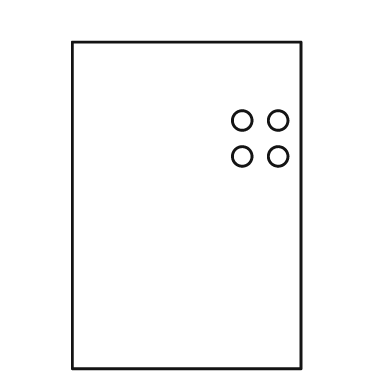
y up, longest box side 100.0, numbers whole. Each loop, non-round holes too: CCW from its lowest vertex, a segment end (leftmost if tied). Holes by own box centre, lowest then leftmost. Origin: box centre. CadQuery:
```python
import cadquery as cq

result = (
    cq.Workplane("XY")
    .moveTo(-35.0, -50.0)
    .lineTo(35.0, -50.0)
    .lineTo(35.0, 50.0)
    .lineTo(-35.0, 50.0)
    .close()
    .moveTo(17.0, 15.0)
    .circle(3.0)
    .moveTo(28.0, 15.0)
    .circle(3.0)
    .moveTo(17.0, 26.0)
    .circle(3.0)
    .moveTo(28.0, 26.0)
    .circle(3.0)
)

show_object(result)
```